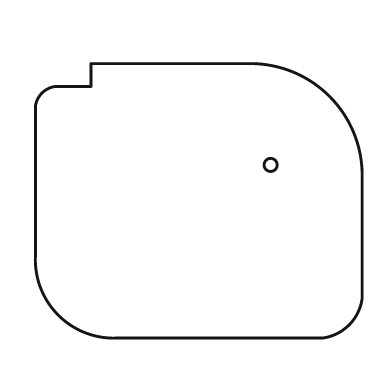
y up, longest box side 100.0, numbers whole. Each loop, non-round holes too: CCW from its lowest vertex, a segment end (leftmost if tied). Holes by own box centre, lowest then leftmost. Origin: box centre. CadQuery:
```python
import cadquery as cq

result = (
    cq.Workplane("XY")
    .moveTo(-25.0, -42.0)
    .lineTo(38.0, -42.0)
    .threePointArc((46.0, -38.0), (50.0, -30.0))
    .lineTo(50.0, 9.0)
    .threePointArc((40.0, 32.0), (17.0, 42.0))
    .lineTo(-33.0, 42.0)
    .lineTo(-33.0, 35.0)
    .lineTo(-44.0, 35.0)
    .threePointArc((-48.0, 33.0), (-50.0, 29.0))
    .lineTo(-50.0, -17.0)
    .threePointArc((-43.0, -35.0), (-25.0, -42.0))
    .close()
    .moveTo(22.0, 11.0)
    .circle(2.0)
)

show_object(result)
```